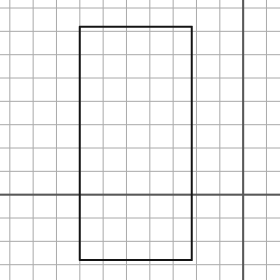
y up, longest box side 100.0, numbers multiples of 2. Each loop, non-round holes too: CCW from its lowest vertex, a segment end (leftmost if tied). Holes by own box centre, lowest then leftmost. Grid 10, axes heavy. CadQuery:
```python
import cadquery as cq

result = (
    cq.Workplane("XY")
    .moveTo(-70.0, -28.0)
    .lineTo(-22.0, -28.0)
    .lineTo(-22.0, 72.0)
    .lineTo(-70.0, 72.0)
    .close()
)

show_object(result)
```